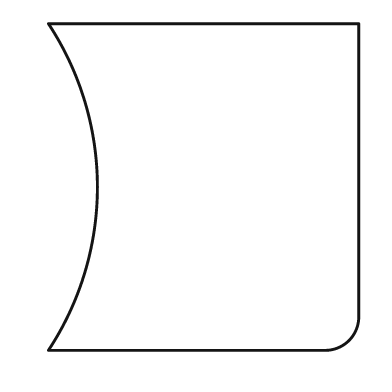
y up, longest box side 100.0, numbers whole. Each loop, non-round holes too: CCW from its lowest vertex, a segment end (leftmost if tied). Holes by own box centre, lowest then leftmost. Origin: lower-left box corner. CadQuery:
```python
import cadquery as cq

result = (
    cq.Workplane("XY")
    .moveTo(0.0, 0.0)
    .lineTo(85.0, 0.0)
    .threePointArc((92.0, 3.0), (95.0, 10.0))
    .lineTo(95.0, 100.0)
    .lineTo(0.0, 100.0)
    .threePointArc((15.0, 50.0), (0.0, 0.0))
    .close()
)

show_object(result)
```